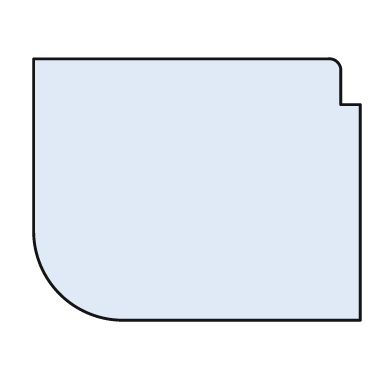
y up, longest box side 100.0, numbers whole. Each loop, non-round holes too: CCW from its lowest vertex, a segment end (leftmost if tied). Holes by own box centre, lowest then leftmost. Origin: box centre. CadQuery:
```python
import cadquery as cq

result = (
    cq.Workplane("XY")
    .moveTo(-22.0, -40.0)
    .lineTo(50.0, -40.0)
    .lineTo(50.0, 26.0)
    .lineTo(44.0, 26.0)
    .lineTo(44.0, 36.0)
    .threePointArc((43.0, 39.0), (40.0, 40.0))
    .lineTo(-50.0, 40.0)
    .lineTo(-50.0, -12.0)
    .threePointArc((-42.0, -32.0), (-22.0, -40.0))
    .close()
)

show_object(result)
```